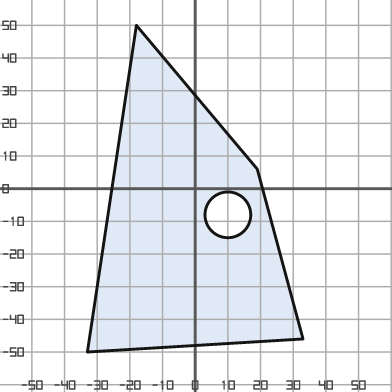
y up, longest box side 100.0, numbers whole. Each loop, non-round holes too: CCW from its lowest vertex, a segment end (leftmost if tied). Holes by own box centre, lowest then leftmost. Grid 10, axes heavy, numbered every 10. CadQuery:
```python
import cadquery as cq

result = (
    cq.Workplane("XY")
    .moveTo(-33.0, -50.0)
    .lineTo(33.0, -46.0)
    .lineTo(19.0, 6.0)
    .lineTo(-18.0, 50.0)
    .close()
    .moveTo(10.0, -8.0)
    .circle(7.0)
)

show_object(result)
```